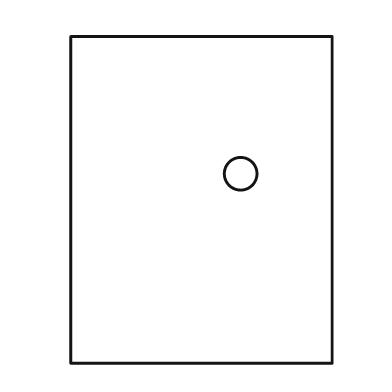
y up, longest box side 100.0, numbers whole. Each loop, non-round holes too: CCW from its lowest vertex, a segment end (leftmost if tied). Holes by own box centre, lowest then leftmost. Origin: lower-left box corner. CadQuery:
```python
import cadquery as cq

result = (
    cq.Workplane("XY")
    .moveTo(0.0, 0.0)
    .lineTo(80.0, 0.0)
    .lineTo(80.0, 100.0)
    .lineTo(0.0, 100.0)
    .close()
    .moveTo(52.0, 58.0)
    .circle(5.0)
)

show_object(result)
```